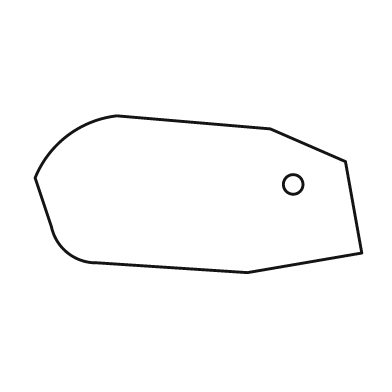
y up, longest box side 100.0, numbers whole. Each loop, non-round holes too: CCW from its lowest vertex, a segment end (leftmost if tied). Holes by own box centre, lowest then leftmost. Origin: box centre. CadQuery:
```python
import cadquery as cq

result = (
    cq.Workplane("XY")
    .moveTo(15.0, -24.0)
    .lineTo(50.0, -18.0)
    .lineTo(45.0, 10.0)
    .lineTo(22.0, 20.0)
    .lineTo(-25.0, 24.0)
    .threePointArc((-40.0, 18.0), (-50.0, 5.0))
    .lineTo(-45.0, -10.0)
    .threePointArc((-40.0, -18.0), (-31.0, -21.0))
    .close()
    .moveTo(29.0, 3.0)
    .circle(3.0)
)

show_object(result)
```